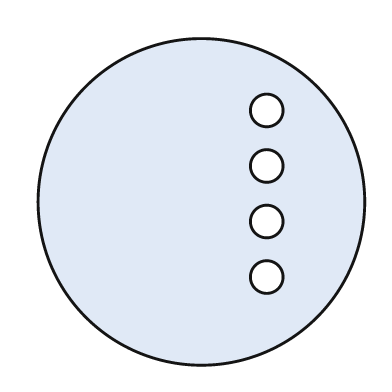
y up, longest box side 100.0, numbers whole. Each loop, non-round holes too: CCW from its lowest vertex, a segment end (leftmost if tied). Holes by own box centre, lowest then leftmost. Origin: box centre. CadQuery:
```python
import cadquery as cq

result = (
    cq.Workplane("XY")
    .moveTo(0.0, 0.0)
    .circle(50.0)
    .moveTo(20.0, -23.0)
    .circle(5.0)
    .moveTo(20.0, -6.0)
    .circle(5.0)
    .moveTo(20.0, 11.0)
    .circle(5.0)
    .moveTo(20.0, 28.0)
    .circle(5.0)
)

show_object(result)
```